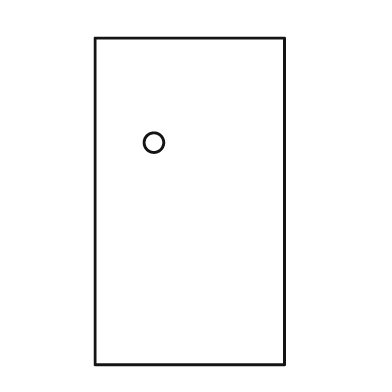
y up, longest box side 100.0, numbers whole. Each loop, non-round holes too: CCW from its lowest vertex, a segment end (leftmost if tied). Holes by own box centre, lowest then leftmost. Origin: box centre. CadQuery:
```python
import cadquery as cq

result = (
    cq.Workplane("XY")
    .moveTo(-29.0, -50.0)
    .lineTo(29.0, -50.0)
    .lineTo(29.0, 50.0)
    .lineTo(-29.0, 50.0)
    .close()
    .moveTo(-11.0, 18.0)
    .circle(3.0)
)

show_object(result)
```